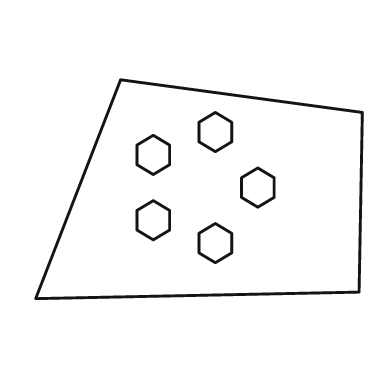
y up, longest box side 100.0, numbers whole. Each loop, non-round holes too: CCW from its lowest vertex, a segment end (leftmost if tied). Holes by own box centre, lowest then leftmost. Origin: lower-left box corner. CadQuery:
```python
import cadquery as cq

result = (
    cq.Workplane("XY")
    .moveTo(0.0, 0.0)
    .lineTo(99.0, 2.0)
    .lineTo(100.0, 57.0)
    .lineTo(26.0, 67.0)
    .close()
    .moveTo(55.0, 11.0)
    .lineTo(60.0, 14.0)
    .lineTo(60.0, 20.0)
    .lineTo(55.0, 23.0)
    .lineTo(50.0, 20.0)
    .lineTo(50.0, 14.0)
    .close()
    .moveTo(36.0, 18.0)
    .lineTo(41.0, 21.0)
    .lineTo(41.0, 27.0)
    .lineTo(36.0, 30.0)
    .lineTo(31.0, 27.0)
    .lineTo(31.0, 21.0)
    .close()
    .moveTo(68.0, 28.0)
    .lineTo(73.0, 31.0)
    .lineTo(73.0, 37.0)
    .lineTo(68.0, 40.0)
    .lineTo(63.0, 37.0)
    .lineTo(63.0, 31.0)
    .close()
    .moveTo(36.0, 38.0)
    .lineTo(41.0, 41.0)
    .lineTo(41.0, 47.0)
    .lineTo(36.0, 50.0)
    .lineTo(31.0, 47.0)
    .lineTo(31.0, 41.0)
    .close()
    .moveTo(55.0, 45.0)
    .lineTo(60.0, 48.0)
    .lineTo(60.0, 54.0)
    .lineTo(55.0, 57.0)
    .lineTo(50.0, 54.0)
    .lineTo(50.0, 48.0)
    .close()
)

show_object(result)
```